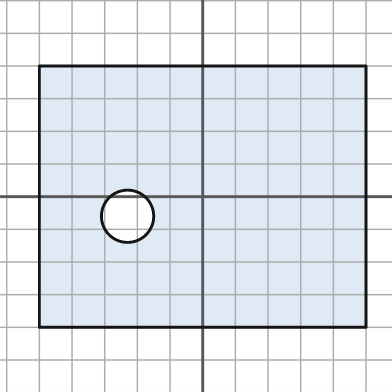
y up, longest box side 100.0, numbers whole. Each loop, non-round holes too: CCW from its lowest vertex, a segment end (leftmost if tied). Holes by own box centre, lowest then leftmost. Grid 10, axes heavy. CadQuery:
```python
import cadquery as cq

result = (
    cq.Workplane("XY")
    .moveTo(-50.0, -40.0)
    .lineTo(50.0, -40.0)
    .lineTo(50.0, 40.0)
    .lineTo(-50.0, 40.0)
    .close()
    .moveTo(-23.0, -6.0)
    .circle(8.0)
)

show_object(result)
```